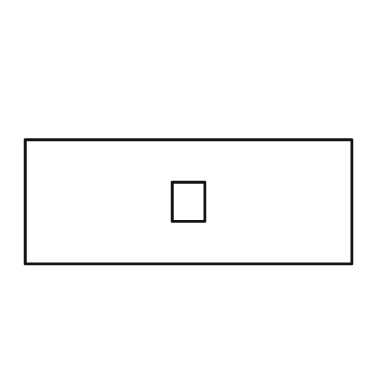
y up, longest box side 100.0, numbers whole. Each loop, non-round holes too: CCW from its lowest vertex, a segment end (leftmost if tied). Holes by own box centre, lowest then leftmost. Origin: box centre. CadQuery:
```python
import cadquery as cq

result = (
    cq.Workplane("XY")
    .moveTo(-50.0, -19.0)
    .lineTo(50.0, -19.0)
    .lineTo(50.0, 19.0)
    .lineTo(-50.0, 19.0)
    .close()
    .moveTo(-5.0, -6.0)
    .lineTo(5.0, -6.0)
    .lineTo(5.0, 6.0)
    .lineTo(-5.0, 6.0)
    .close()
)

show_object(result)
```